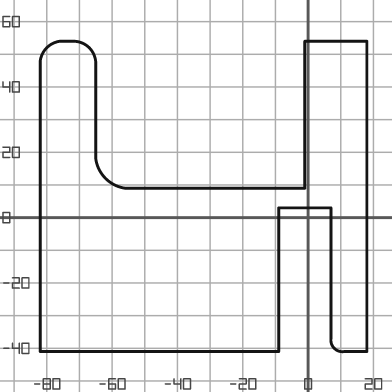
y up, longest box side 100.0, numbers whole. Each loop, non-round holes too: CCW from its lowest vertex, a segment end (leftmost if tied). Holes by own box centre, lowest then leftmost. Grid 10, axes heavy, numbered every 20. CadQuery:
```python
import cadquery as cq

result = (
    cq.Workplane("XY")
    .moveTo(-82.0, -41.0)
    .lineTo(-9.0, -41.0)
    .lineTo(-9.0, 3.0)
    .lineTo(7.0, 3.0)
    .lineTo(7.0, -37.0)
    .threePointArc((8.0, -40.0), (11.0, -41.0))
    .lineTo(18.0, -41.0)
    .lineTo(18.0, 54.0)
    .lineTo(-1.0, 54.0)
    .lineTo(-1.0, 9.0)
    .lineTo(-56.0, 9.0)
    .threePointArc((-62.0, 12.0), (-65.0, 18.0))
    .lineTo(-65.0, 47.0)
    .threePointArc((-67.0, 52.0), (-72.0, 54.0))
    .lineTo(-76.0, 54.0)
    .threePointArc((-80.0, 52.0), (-82.0, 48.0))
    .close()
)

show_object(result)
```